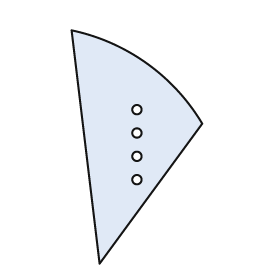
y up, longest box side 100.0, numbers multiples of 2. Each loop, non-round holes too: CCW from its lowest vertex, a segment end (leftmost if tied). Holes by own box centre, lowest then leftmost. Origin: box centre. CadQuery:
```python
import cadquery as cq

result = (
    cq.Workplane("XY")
    .moveTo(-16.0, -50.0)
    .lineTo(28.0, 10.0)
    .threePointArc((4.0, 36.0), (-28.0, 50.0))
    .close()
    .moveTo(0.0, -14.0)
    .circle(2.0)
    .moveTo(0.0, -4.0)
    .circle(2.0)
    .moveTo(0.0, 6.0)
    .circle(2.0)
    .moveTo(0.0, 16.0)
    .circle(2.0)
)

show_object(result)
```